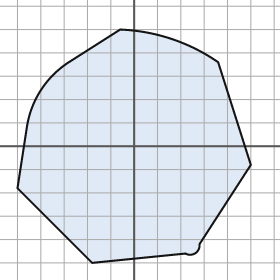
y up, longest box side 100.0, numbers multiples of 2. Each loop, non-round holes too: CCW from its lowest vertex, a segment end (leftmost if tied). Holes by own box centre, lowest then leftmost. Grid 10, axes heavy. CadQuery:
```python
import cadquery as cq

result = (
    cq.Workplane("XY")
    .moveTo(-18.0, -50.0)
    .lineTo(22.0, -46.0)
    .threePointArc((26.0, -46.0), (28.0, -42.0))
    .lineTo(50.0, -8.0)
    .lineTo(36.0, 36.0)
    .threePointArc((16.0, 46.0), (-6.0, 50.0))
    .lineTo(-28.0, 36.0)
    .threePointArc((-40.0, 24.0), (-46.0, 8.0))
    .lineTo(-50.0, -18.0)
    .close()
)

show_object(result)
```